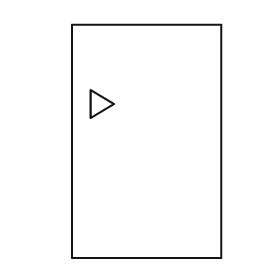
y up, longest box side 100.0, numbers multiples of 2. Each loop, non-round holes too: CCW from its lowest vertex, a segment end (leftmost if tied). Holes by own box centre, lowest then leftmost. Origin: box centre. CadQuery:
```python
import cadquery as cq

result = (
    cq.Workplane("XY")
    .moveTo(-32.0, -50.0)
    .lineTo(32.0, -50.0)
    .lineTo(32.0, 50.0)
    .lineTo(-32.0, 50.0)
    .close()
    .moveTo(-24.0, 10.0)
    .lineTo(-14.0, 16.0)
    .lineTo(-24.0, 22.0)
    .close()
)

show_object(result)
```